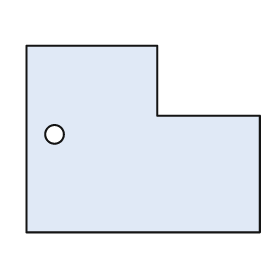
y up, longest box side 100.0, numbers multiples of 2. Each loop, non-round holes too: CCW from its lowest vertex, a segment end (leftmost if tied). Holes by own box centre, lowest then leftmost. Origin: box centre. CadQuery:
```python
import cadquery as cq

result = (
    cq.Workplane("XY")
    .moveTo(-50.0, -40.0)
    .lineTo(50.0, -40.0)
    .lineTo(50.0, 10.0)
    .lineTo(6.0, 10.0)
    .lineTo(6.0, 40.0)
    .lineTo(-50.0, 40.0)
    .close()
    .moveTo(-38.0, 2.0)
    .circle(4.0)
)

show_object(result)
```